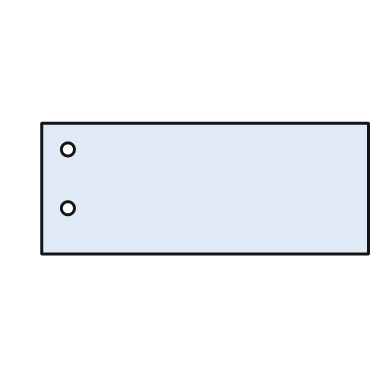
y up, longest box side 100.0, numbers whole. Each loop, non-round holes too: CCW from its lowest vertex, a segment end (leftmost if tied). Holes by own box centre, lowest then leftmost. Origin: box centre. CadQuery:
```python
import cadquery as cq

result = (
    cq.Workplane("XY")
    .moveTo(-50.0, -20.0)
    .lineTo(50.0, -20.0)
    .lineTo(50.0, 20.0)
    .lineTo(-50.0, 20.0)
    .close()
    .moveTo(-42.0, -6.0)
    .circle(2.0)
    .moveTo(-42.0, 12.0)
    .circle(2.0)
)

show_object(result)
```